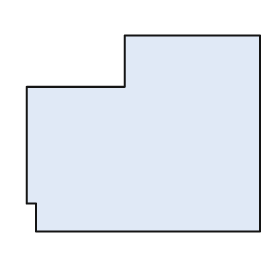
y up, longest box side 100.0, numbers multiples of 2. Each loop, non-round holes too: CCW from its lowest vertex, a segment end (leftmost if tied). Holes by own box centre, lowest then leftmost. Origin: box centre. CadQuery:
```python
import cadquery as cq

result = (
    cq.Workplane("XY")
    .moveTo(-46.0, -42.0)
    .lineTo(50.0, -42.0)
    .lineTo(50.0, 42.0)
    .lineTo(-8.0, 42.0)
    .lineTo(-8.0, 20.0)
    .lineTo(-50.0, 20.0)
    .lineTo(-50.0, -30.0)
    .lineTo(-46.0, -30.0)
    .close()
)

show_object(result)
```